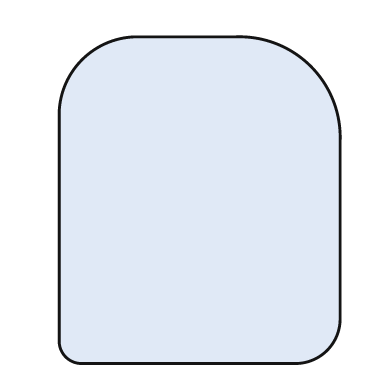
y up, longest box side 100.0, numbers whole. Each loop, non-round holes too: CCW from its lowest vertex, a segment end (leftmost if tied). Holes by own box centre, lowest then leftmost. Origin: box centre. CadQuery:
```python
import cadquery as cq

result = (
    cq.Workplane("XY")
    .moveTo(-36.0, -50.0)
    .lineTo(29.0, -50.0)
    .threePointArc((39.0, -46.0), (43.0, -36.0))
    .lineTo(43.0, 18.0)
    .threePointArc((34.0, 41.0), (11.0, 50.0))
    .lineTo(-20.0, 50.0)
    .threePointArc((-36.0, 43.0), (-43.0, 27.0))
    .lineTo(-43.0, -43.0)
    .threePointArc((-41.0, -48.0), (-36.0, -50.0))
    .close()
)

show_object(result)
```